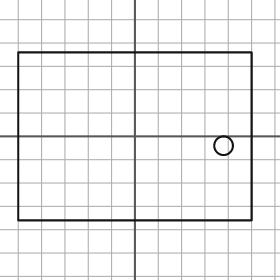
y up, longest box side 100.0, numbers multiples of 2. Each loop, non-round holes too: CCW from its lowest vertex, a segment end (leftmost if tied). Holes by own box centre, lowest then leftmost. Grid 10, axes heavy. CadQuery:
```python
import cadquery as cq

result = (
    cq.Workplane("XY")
    .moveTo(-50.0, -36.0)
    .lineTo(50.0, -36.0)
    .lineTo(50.0, 36.0)
    .lineTo(-50.0, 36.0)
    .close()
    .moveTo(38.0, -4.0)
    .circle(4.0)
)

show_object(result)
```